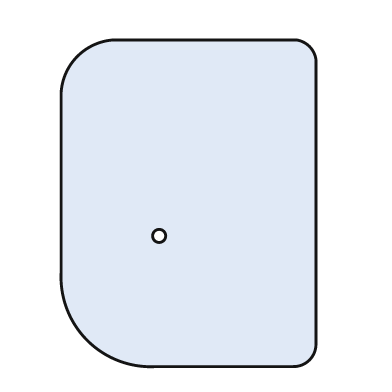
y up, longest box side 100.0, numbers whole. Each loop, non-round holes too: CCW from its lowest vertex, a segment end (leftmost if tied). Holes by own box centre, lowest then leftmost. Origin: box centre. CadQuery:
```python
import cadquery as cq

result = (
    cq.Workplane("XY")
    .moveTo(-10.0, -50.0)
    .lineTo(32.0, -50.0)
    .threePointArc((37.0, -48.0), (39.0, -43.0))
    .lineTo(39.0, 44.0)
    .threePointArc((37.0, 48.0), (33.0, 50.0))
    .lineTo(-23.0, 50.0)
    .threePointArc((-34.0, 45.0), (-39.0, 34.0))
    .lineTo(-39.0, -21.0)
    .threePointArc((-31.0, -42.0), (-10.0, -50.0))
    .close()
    .moveTo(-9.0, -10.0)
    .circle(2.0)
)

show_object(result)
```